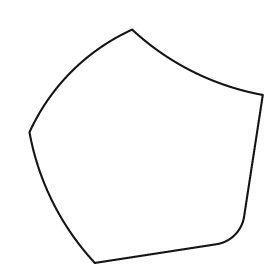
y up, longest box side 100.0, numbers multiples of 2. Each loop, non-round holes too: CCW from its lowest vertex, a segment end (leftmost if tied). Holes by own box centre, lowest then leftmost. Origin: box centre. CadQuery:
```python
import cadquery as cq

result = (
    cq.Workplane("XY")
    .moveTo(-22.0, -50.0)
    .lineTo(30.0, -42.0)
    .threePointArc((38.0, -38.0), (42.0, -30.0))
    .lineTo(50.0, 22.0)
    .threePointArc((20.0, 32.0), (-6.0, 50.0))
    .threePointArc((-32.0, 32.0), (-50.0, 6.0))
    .threePointArc((-40.0, -24.0), (-22.0, -50.0))
    .close()
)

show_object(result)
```